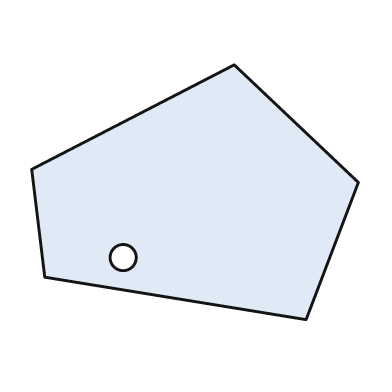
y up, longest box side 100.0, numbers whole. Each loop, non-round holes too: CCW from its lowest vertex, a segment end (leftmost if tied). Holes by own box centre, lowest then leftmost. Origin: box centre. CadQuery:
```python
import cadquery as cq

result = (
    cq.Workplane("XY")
    .moveTo(34.0, -39.0)
    .lineTo(50.0, 3.0)
    .lineTo(12.0, 39.0)
    .lineTo(-50.0, 7.0)
    .lineTo(-46.0, -26.0)
    .close()
    .moveTo(-22.0, -20.0)
    .circle(4.0)
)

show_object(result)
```